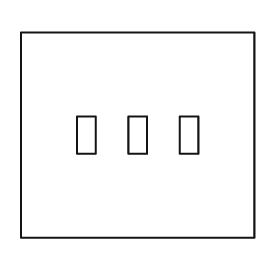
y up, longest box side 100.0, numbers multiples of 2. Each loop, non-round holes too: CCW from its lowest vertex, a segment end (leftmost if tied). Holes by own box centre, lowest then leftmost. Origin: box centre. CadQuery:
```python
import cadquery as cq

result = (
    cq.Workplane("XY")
    .moveTo(-50.0, -44.0)
    .lineTo(50.0, -44.0)
    .lineTo(50.0, 44.0)
    .lineTo(-50.0, 44.0)
    .close()
    .moveTo(-26.0, -8.0)
    .lineTo(-18.0, -8.0)
    .lineTo(-18.0, 8.0)
    .lineTo(-26.0, 8.0)
    .close()
    .moveTo(-4.0, -8.0)
    .lineTo(4.0, -8.0)
    .lineTo(4.0, 8.0)
    .lineTo(-4.0, 8.0)
    .close()
    .moveTo(18.0, -8.0)
    .lineTo(26.0, -8.0)
    .lineTo(26.0, 8.0)
    .lineTo(18.0, 8.0)
    .close()
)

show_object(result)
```